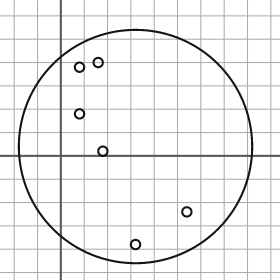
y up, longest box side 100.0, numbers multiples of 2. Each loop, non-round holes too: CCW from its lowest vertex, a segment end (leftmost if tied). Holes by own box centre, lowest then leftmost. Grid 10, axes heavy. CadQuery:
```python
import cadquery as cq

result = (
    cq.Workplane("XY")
    .moveTo(32.0, 4.0)
    .circle(50.0)
    .moveTo(32.0, -38.0)
    .circle(2.0)
    .moveTo(54.0, -24.0)
    .circle(2.0)
    .moveTo(18.0, 2.0)
    .circle(2.0)
    .moveTo(8.0, 18.0)
    .circle(2.0)
    .moveTo(8.0, 38.0)
    .circle(2.0)
    .moveTo(16.0, 40.0)
    .circle(2.0)
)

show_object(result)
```